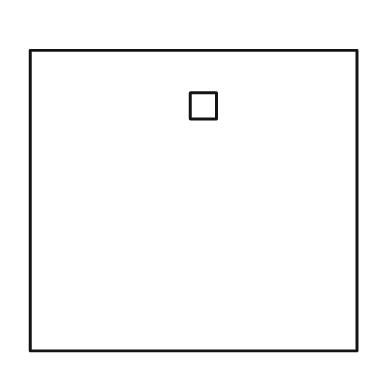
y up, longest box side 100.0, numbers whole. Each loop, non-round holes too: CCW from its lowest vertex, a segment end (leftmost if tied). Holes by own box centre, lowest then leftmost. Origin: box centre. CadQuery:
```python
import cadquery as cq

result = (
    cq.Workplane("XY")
    .moveTo(-50.0, -46.0)
    .lineTo(50.0, -46.0)
    .lineTo(50.0, 46.0)
    .lineTo(-50.0, 46.0)
    .close()
    .moveTo(-1.0, 25.0)
    .lineTo(7.0, 25.0)
    .lineTo(7.0, 33.0)
    .lineTo(-1.0, 33.0)
    .close()
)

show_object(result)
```